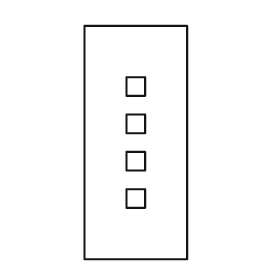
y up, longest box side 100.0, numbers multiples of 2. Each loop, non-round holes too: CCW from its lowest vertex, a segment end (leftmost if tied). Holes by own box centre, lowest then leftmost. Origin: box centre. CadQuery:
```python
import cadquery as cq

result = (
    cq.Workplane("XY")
    .moveTo(-22.0, -50.0)
    .lineTo(22.0, -50.0)
    .lineTo(22.0, 50.0)
    .lineTo(-22.0, 50.0)
    .close()
    .moveTo(-4.0, -28.0)
    .lineTo(4.0, -28.0)
    .lineTo(4.0, -20.0)
    .lineTo(-4.0, -20.0)
    .close()
    .moveTo(-4.0, -12.0)
    .lineTo(4.0, -12.0)
    .lineTo(4.0, -4.0)
    .lineTo(-4.0, -4.0)
    .close()
    .moveTo(-4.0, 4.0)
    .lineTo(4.0, 4.0)
    .lineTo(4.0, 12.0)
    .lineTo(-4.0, 12.0)
    .close()
    .moveTo(-4.0, 20.0)
    .lineTo(4.0, 20.0)
    .lineTo(4.0, 28.0)
    .lineTo(-4.0, 28.0)
    .close()
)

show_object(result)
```